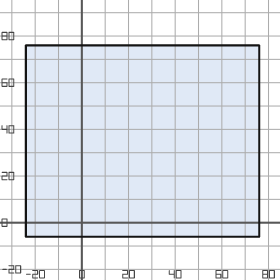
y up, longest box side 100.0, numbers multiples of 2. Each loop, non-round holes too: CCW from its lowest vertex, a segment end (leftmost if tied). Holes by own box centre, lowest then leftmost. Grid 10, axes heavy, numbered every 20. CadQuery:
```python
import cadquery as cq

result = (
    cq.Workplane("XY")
    .moveTo(-24.0, -6.0)
    .lineTo(76.0, -6.0)
    .lineTo(76.0, 76.0)
    .lineTo(-24.0, 76.0)
    .close()
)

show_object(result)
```